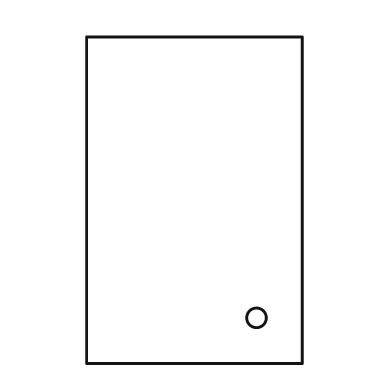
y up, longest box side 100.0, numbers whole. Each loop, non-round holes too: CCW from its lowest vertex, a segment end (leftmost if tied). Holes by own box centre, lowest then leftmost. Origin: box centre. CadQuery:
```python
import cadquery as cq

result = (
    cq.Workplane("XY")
    .moveTo(-33.0, -50.0)
    .lineTo(33.0, -50.0)
    .lineTo(33.0, 50.0)
    .lineTo(-33.0, 50.0)
    .close()
    .moveTo(19.0, -36.0)
    .circle(3.0)
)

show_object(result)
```